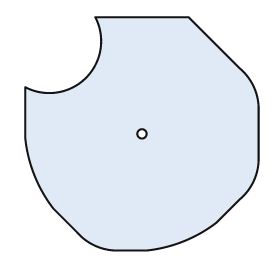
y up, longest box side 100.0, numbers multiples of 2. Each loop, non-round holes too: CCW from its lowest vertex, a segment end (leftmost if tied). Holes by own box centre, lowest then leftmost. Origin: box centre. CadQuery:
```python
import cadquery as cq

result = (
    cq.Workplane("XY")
    .moveTo(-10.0, -50.0)
    .lineTo(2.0, -50.0)
    .threePointArc((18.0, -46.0), (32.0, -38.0))
    .lineTo(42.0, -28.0)
    .threePointArc((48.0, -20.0), (50.0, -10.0))
    .lineTo(50.0, 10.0)
    .threePointArc((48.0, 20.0), (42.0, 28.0))
    .lineTo(20.0, 50.0)
    .lineTo(-20.0, 50.0)
    .threePointArc((-24.0, 24.0), (-50.0, 20.0))
    .lineTo(-50.0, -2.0)
    .threePointArc((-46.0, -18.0), (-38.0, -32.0))
    .lineTo(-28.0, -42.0)
    .threePointArc((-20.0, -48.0), (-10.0, -50.0))
    .close()
    .moveTo(0.0, 0.0)
    .circle(2.0)
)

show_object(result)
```